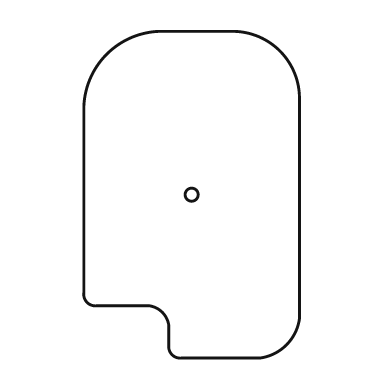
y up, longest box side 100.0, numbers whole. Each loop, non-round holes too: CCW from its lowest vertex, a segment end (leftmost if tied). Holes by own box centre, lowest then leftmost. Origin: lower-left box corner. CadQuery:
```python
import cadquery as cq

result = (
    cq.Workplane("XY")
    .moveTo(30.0, 0.0)
    .lineTo(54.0, 0.0)
    .threePointArc((62.0, 4.0), (66.0, 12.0))
    .lineTo(66.0, 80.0)
    .threePointArc((60.0, 94.0), (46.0, 100.0))
    .lineTo(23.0, 100.0)
    .threePointArc((7.0, 93.0), (0.0, 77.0))
    .lineTo(0.0, 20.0)
    .threePointArc((1.0, 17.0), (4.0, 16.0))
    .lineTo(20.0, 16.0)
    .threePointArc((24.0, 14.0), (26.0, 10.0))
    .lineTo(26.0, 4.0)
    .threePointArc((27.0, 1.0), (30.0, 0.0))
    .close()
    .moveTo(33.0, 50.0)
    .circle(2.0)
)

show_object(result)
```